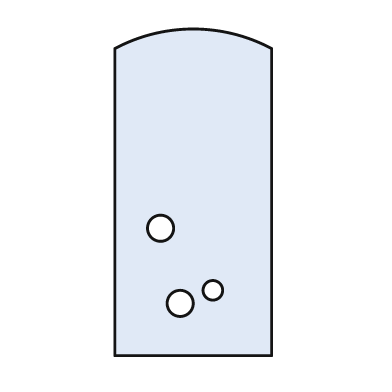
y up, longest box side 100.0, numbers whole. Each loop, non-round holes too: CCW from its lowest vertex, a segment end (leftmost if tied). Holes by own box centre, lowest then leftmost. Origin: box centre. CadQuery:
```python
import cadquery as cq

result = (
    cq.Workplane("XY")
    .moveTo(-24.0, -50.0)
    .lineTo(24.0, -50.0)
    .lineTo(24.0, 44.0)
    .threePointArc((0.0, 50.0), (-24.0, 44.0))
    .close()
    .moveTo(-4.0, -34.0)
    .circle(4.0)
    .moveTo(6.0, -30.0)
    .circle(3.0)
    .moveTo(-10.0, -11.0)
    .circle(4.0)
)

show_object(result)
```